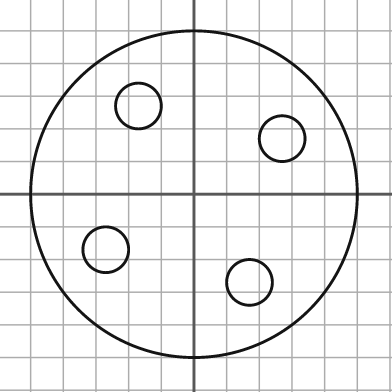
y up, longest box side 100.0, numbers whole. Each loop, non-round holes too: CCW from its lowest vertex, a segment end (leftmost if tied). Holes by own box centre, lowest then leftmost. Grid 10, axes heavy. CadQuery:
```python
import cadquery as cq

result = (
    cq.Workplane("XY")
    .moveTo(0.0, 0.0)
    .circle(50.0)
    .moveTo(17.0, -27.0)
    .circle(7.0)
    .moveTo(-27.0, -17.0)
    .circle(7.0)
    .moveTo(27.0, 17.0)
    .circle(7.0)
    .moveTo(-17.0, 27.0)
    .circle(7.0)
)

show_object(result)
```